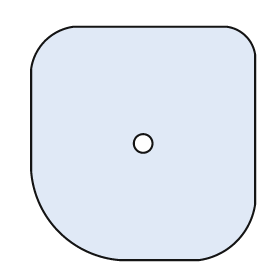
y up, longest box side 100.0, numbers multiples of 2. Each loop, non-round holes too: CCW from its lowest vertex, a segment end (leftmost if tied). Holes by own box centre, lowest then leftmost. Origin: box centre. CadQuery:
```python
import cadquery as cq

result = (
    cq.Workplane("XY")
    .moveTo(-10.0, -50.0)
    .lineTo(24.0, -50.0)
    .threePointArc((40.0, -42.0), (48.0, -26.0))
    .lineTo(48.0, 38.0)
    .threePointArc((44.0, 46.0), (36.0, 50.0))
    .lineTo(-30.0, 50.0)
    .threePointArc((-42.0, 44.0), (-48.0, 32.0))
    .lineTo(-48.0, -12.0)
    .threePointArc((-36.0, -38.0), (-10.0, -50.0))
    .close()
    .moveTo(0.0, 0.0)
    .circle(4.0)
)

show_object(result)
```